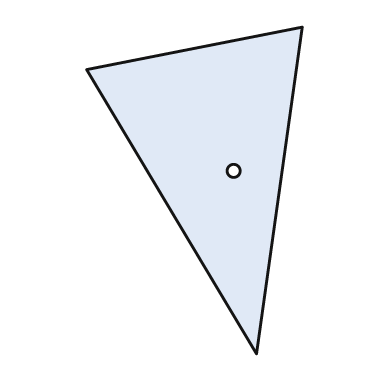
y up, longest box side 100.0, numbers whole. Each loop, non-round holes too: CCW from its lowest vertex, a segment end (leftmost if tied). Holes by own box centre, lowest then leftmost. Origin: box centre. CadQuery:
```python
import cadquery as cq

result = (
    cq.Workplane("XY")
    .moveTo(19.0, -50.0)
    .lineTo(33.0, 50.0)
    .lineTo(-33.0, 37.0)
    .close()
    .moveTo(12.0, 6.0)
    .circle(2.0)
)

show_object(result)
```